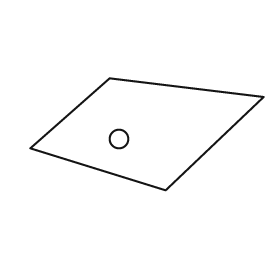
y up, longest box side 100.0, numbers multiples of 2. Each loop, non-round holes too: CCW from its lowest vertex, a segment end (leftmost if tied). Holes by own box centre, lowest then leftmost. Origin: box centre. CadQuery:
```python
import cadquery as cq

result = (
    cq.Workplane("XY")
    .moveTo(8.0, -24.0)
    .lineTo(50.0, 16.0)
    .lineTo(-16.0, 24.0)
    .lineTo(-50.0, -6.0)
    .close()
    .moveTo(-12.0, -2.0)
    .circle(4.0)
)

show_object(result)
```